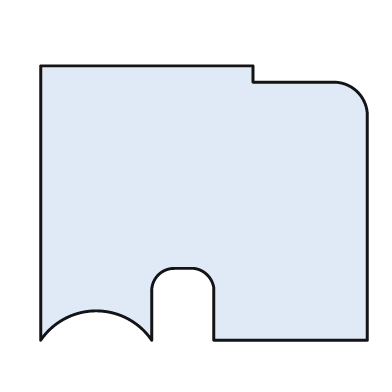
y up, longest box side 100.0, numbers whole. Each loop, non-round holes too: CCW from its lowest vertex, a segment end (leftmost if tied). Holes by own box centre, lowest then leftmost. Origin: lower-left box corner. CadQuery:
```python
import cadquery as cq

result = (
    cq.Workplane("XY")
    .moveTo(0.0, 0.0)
    .threePointArc((17.0, 9.0), (34.0, 0.0))
    .lineTo(34.0, 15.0)
    .threePointArc((36.0, 20.0), (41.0, 22.0))
    .lineTo(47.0, 22.0)
    .threePointArc((51.0, 20.0), (53.0, 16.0))
    .lineTo(53.0, 0.0)
    .lineTo(100.0, 0.0)
    .lineTo(100.0, 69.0)
    .threePointArc((97.0, 76.0), (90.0, 79.0))
    .lineTo(65.0, 79.0)
    .lineTo(65.0, 84.0)
    .lineTo(0.0, 84.0)
    .close()
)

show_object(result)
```